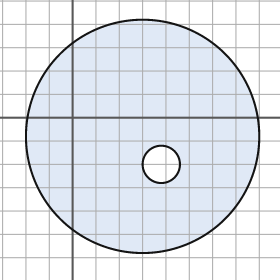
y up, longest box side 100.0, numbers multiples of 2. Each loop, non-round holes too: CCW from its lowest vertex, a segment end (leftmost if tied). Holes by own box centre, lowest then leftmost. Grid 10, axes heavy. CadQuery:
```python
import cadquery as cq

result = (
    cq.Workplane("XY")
    .moveTo(30.0, -8.0)
    .circle(50.0)
    .moveTo(38.0, -20.0)
    .circle(8.0)
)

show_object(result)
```